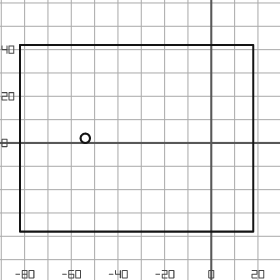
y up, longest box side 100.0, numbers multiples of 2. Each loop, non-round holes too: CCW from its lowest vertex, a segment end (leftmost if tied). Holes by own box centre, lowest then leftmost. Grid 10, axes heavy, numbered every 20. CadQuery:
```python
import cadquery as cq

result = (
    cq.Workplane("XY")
    .moveTo(-82.0, -38.0)
    .lineTo(18.0, -38.0)
    .lineTo(18.0, 42.0)
    .lineTo(-82.0, 42.0)
    .close()
    .moveTo(-54.0, 2.0)
    .circle(2.0)
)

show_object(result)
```